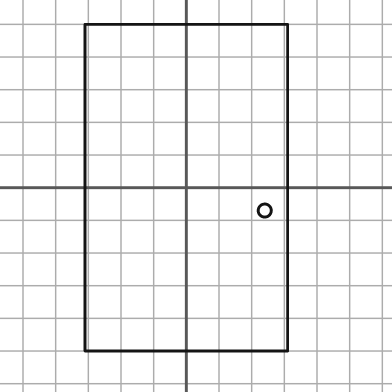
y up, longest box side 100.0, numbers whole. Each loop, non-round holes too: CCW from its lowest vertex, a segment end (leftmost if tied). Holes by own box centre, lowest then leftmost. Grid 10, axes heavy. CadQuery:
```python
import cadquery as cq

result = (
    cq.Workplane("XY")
    .moveTo(-31.0, -50.0)
    .lineTo(31.0, -50.0)
    .lineTo(31.0, 50.0)
    .lineTo(-31.0, 50.0)
    .close()
    .moveTo(24.0, -7.0)
    .circle(2.0)
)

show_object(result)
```